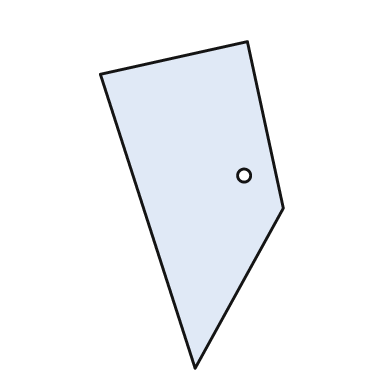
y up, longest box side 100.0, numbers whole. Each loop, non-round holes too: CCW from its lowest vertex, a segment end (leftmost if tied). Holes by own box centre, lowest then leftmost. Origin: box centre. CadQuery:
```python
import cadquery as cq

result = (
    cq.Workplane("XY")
    .moveTo(1.0, -50.0)
    .lineTo(28.0, -1.0)
    .lineTo(17.0, 50.0)
    .lineTo(-28.0, 40.0)
    .close()
    .moveTo(16.0, 9.0)
    .circle(2.0)
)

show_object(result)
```